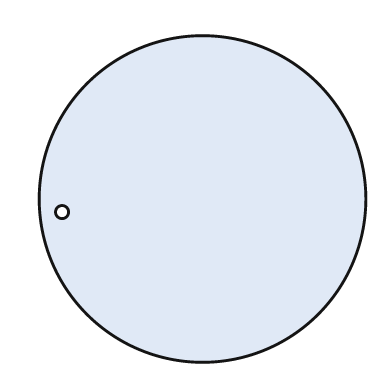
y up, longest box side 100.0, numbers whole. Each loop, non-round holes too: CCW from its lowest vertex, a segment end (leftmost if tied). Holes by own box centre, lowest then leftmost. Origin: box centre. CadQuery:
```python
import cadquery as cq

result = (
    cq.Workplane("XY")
    .moveTo(0.0, 0.0)
    .circle(50.0)
    .moveTo(-43.0, -4.0)
    .circle(2.0)
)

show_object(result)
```